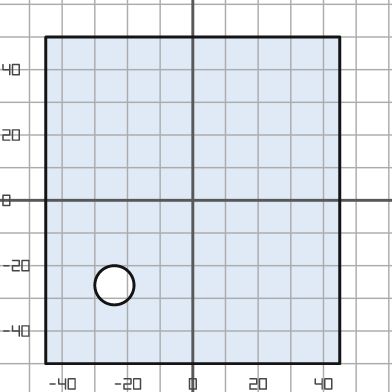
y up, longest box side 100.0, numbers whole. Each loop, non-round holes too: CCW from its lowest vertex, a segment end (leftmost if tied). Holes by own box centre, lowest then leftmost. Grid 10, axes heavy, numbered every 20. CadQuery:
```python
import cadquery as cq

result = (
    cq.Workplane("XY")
    .moveTo(-45.0, -50.0)
    .lineTo(45.0, -50.0)
    .lineTo(45.0, 50.0)
    .lineTo(-45.0, 50.0)
    .close()
    .moveTo(-24.0, -26.0)
    .circle(6.0)
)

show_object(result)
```